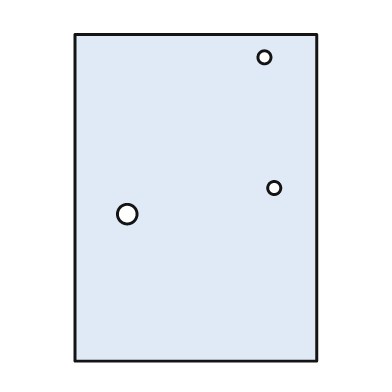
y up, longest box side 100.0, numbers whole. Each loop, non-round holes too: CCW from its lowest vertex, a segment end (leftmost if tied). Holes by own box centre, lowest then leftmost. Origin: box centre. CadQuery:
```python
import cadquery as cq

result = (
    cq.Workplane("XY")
    .moveTo(-37.0, -50.0)
    .lineTo(37.0, -50.0)
    .lineTo(37.0, 50.0)
    .lineTo(-37.0, 50.0)
    .close()
    .moveTo(-21.0, -5.0)
    .circle(3.0)
    .moveTo(24.0, 3.0)
    .circle(2.0)
    .moveTo(21.0, 43.0)
    .circle(2.0)
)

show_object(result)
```